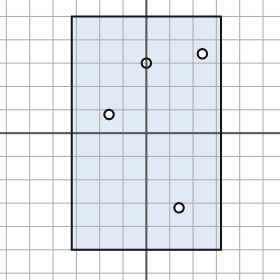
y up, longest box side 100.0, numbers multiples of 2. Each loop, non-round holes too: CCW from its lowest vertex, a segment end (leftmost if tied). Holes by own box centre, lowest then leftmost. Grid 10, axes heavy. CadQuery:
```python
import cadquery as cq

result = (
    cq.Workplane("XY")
    .moveTo(-32.0, -50.0)
    .lineTo(32.0, -50.0)
    .lineTo(32.0, 50.0)
    .lineTo(-32.0, 50.0)
    .close()
    .moveTo(14.0, -32.0)
    .circle(2.0)
    .moveTo(-16.0, 8.0)
    .circle(2.0)
    .moveTo(0.0, 30.0)
    .circle(2.0)
    .moveTo(24.0, 34.0)
    .circle(2.0)
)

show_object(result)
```